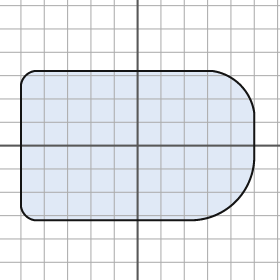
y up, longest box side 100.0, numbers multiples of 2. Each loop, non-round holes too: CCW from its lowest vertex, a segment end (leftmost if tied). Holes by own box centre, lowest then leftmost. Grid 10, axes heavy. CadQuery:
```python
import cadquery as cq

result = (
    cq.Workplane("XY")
    .moveTo(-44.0, -32.0)
    .lineTo(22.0, -32.0)
    .threePointArc((42.0, -24.0), (50.0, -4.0))
    .lineTo(50.0, 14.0)
    .threePointArc((44.0, 26.0), (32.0, 32.0))
    .lineTo(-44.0, 32.0)
    .threePointArc((-48.0, 30.0), (-50.0, 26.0))
    .lineTo(-50.0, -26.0)
    .threePointArc((-48.0, -30.0), (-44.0, -32.0))
    .close()
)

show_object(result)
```